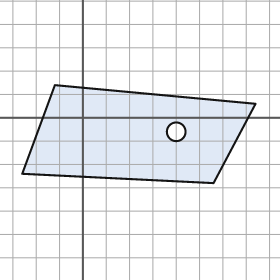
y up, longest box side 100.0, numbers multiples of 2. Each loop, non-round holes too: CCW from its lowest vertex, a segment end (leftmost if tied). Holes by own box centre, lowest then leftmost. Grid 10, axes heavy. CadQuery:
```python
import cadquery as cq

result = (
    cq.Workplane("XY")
    .moveTo(56.0, -28.0)
    .lineTo(74.0, 6.0)
    .lineTo(-12.0, 14.0)
    .lineTo(-26.0, -24.0)
    .close()
    .moveTo(40.0, -6.0)
    .circle(4.0)
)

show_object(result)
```